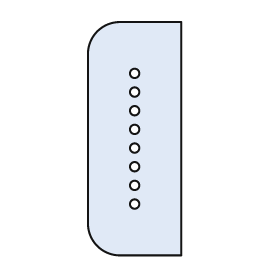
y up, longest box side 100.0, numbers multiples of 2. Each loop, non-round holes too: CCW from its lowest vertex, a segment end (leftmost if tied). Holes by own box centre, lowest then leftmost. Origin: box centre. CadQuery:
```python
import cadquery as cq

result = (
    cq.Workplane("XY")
    .moveTo(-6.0, -50.0)
    .lineTo(20.0, -50.0)
    .lineTo(20.0, 50.0)
    .lineTo(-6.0, 50.0)
    .threePointArc((-16.0, 46.0), (-20.0, 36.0))
    .lineTo(-20.0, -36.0)
    .threePointArc((-16.0, -46.0), (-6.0, -50.0))
    .close()
    .moveTo(0.0, -28.0)
    .circle(2.0)
    .moveTo(0.0, -20.0)
    .circle(2.0)
    .moveTo(0.0, -12.0)
    .circle(2.0)
    .moveTo(0.0, -4.0)
    .circle(2.0)
    .moveTo(0.0, 4.0)
    .circle(2.0)
    .moveTo(0.0, 12.0)
    .circle(2.0)
    .moveTo(0.0, 20.0)
    .circle(2.0)
    .moveTo(0.0, 28.0)
    .circle(2.0)
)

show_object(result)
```